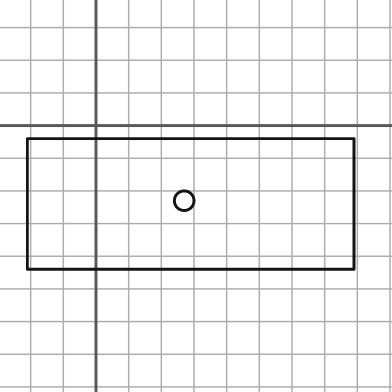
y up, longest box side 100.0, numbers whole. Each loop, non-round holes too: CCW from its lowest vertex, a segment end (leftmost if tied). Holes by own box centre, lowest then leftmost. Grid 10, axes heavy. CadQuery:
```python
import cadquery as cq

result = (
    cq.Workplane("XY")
    .moveTo(-21.0, -44.0)
    .lineTo(79.0, -44.0)
    .lineTo(79.0, -4.0)
    .lineTo(-21.0, -4.0)
    .close()
    .moveTo(27.0, -23.0)
    .circle(3.0)
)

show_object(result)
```